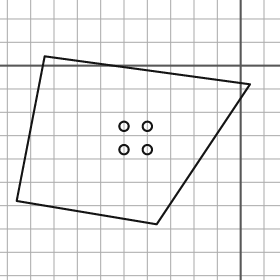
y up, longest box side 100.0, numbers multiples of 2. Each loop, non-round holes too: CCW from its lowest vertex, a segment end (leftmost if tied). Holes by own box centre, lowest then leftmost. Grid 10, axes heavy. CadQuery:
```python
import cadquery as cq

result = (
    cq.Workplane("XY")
    .moveTo(-36.0, -68.0)
    .lineTo(4.0, -8.0)
    .lineTo(-84.0, 4.0)
    .lineTo(-96.0, -58.0)
    .close()
    .moveTo(-50.0, -36.0)
    .circle(2.0)
    .moveTo(-40.0, -36.0)
    .circle(2.0)
    .moveTo(-50.0, -26.0)
    .circle(2.0)
    .moveTo(-40.0, -26.0)
    .circle(2.0)
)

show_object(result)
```